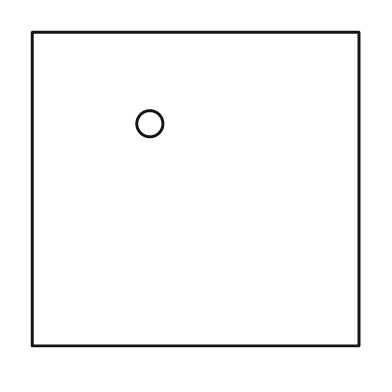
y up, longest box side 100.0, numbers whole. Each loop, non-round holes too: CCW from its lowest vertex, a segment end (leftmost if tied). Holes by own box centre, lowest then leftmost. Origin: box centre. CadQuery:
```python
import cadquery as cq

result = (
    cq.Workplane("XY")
    .moveTo(-50.0, -48.0)
    .lineTo(50.0, -48.0)
    .lineTo(50.0, 48.0)
    .lineTo(-50.0, 48.0)
    .close()
    .moveTo(-14.0, 20.0)
    .circle(4.0)
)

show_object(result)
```